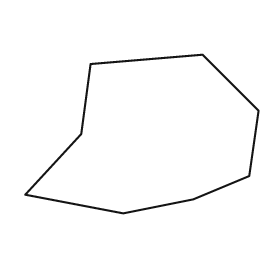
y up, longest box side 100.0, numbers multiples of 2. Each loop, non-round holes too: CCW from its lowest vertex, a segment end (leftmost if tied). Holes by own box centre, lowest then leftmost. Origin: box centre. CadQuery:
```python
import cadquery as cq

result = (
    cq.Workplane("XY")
    .moveTo(-8.0, -34.0)
    .lineTo(22.0, -28.0)
    .lineTo(46.0, -18.0)
    .lineTo(50.0, 10.0)
    .lineTo(26.0, 34.0)
    .lineTo(-22.0, 30.0)
    .lineTo(-26.0, 0.0)
    .lineTo(-50.0, -26.0)
    .close()
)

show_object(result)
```